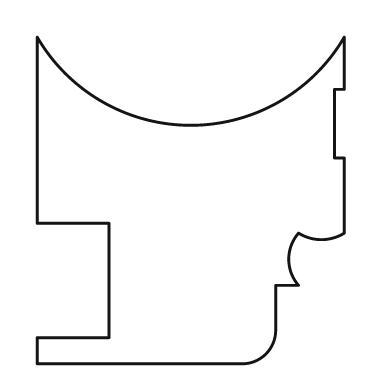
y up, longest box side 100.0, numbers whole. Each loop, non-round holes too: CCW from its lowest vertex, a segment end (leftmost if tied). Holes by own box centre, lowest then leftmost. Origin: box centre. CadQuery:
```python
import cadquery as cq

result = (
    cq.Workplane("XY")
    .moveTo(-47.0, -50.0)
    .lineTo(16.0, -50.0)
    .threePointArc((23.0, -47.0), (26.0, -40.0))
    .lineTo(26.0, -26.0)
    .lineTo(33.0, -26.0)
    .threePointArc((30.0, -18.0), (33.0, -10.0))
    .threePointArc((40.0, -12.0), (47.0, -10.0))
    .lineTo(47.0, 13.0)
    .lineTo(44.0, 13.0)
    .lineTo(44.0, 34.0)
    .lineTo(47.0, 34.0)
    .lineTo(47.0, 50.0)
    .threePointArc((0.0, 23.0), (-47.0, 50.0))
    .lineTo(-47.0, -7.0)
    .lineTo(-25.0, -7.0)
    .lineTo(-25.0, -42.0)
    .lineTo(-47.0, -42.0)
    .close()
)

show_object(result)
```